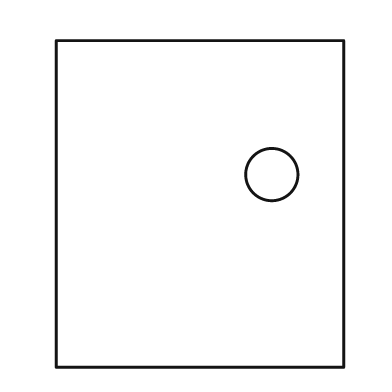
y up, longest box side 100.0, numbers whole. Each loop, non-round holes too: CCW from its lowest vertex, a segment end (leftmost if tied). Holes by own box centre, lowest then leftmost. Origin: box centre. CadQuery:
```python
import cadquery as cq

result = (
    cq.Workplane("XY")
    .moveTo(-44.0, -50.0)
    .lineTo(44.0, -50.0)
    .lineTo(44.0, 50.0)
    .lineTo(-44.0, 50.0)
    .close()
    .moveTo(22.0, 9.0)
    .circle(8.0)
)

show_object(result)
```